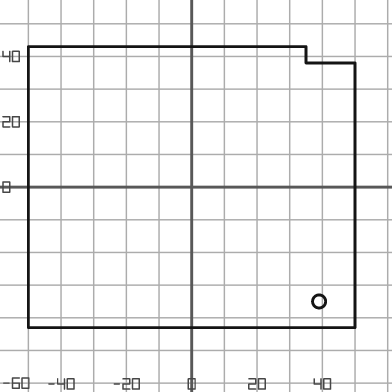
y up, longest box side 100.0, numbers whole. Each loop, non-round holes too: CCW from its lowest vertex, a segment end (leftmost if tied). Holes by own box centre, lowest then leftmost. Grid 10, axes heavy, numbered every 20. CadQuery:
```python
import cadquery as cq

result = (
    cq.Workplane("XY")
    .moveTo(-50.0, -43.0)
    .lineTo(50.0, -43.0)
    .lineTo(50.0, 38.0)
    .lineTo(35.0, 38.0)
    .lineTo(35.0, 43.0)
    .lineTo(-50.0, 43.0)
    .close()
    .moveTo(39.0, -35.0)
    .circle(2.0)
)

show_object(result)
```